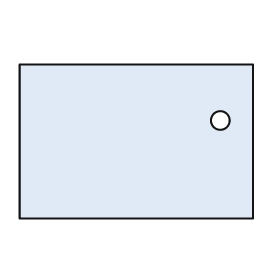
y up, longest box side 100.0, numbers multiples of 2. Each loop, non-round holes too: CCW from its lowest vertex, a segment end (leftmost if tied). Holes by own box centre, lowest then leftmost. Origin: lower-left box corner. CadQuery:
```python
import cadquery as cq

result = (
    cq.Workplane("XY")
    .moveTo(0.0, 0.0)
    .lineTo(100.0, 0.0)
    .lineTo(100.0, 66.0)
    .lineTo(0.0, 66.0)
    .close()
    .moveTo(86.0, 42.0)
    .circle(4.0)
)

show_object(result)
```